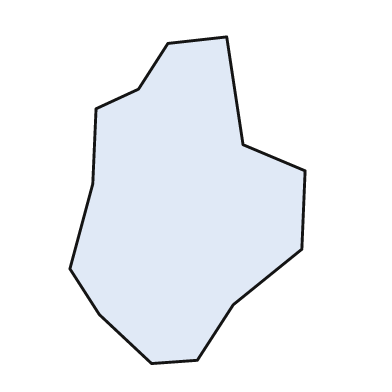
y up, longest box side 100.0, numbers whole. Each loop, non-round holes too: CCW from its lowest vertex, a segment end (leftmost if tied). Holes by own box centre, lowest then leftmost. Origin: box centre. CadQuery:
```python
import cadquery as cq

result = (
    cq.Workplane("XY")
    .moveTo(-11.0, -50.0)
    .lineTo(3.0, -49.0)
    .lineTo(14.0, -32.0)
    .lineTo(35.0, -15.0)
    .lineTo(36.0, 9.0)
    .lineTo(17.0, 17.0)
    .lineTo(12.0, 50.0)
    .lineTo(-6.0, 48.0)
    .lineTo(-15.0, 34.0)
    .lineTo(-28.0, 28.0)
    .lineTo(-29.0, 5.0)
    .lineTo(-36.0, -21.0)
    .lineTo(-27.0, -35.0)
    .close()
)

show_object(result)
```